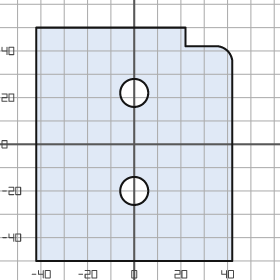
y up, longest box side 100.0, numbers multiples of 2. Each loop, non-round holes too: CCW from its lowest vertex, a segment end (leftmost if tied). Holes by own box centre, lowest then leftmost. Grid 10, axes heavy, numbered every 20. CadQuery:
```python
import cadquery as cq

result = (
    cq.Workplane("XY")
    .moveTo(-42.0, -50.0)
    .lineTo(42.0, -50.0)
    .lineTo(42.0, 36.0)
    .threePointArc((40.0, 40.0), (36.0, 42.0))
    .lineTo(22.0, 42.0)
    .lineTo(22.0, 50.0)
    .lineTo(-42.0, 50.0)
    .close()
    .moveTo(0.0, -20.0)
    .circle(6.0)
    .moveTo(0.0, 22.0)
    .circle(6.0)
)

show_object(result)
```